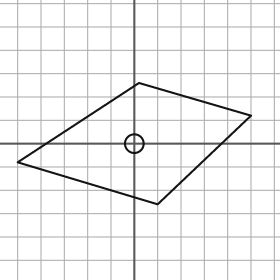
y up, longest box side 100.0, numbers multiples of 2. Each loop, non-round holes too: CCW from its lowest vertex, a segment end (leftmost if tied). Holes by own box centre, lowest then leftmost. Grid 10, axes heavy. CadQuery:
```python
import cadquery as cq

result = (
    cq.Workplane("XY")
    .moveTo(10.0, -26.0)
    .lineTo(50.0, 12.0)
    .lineTo(2.0, 26.0)
    .lineTo(-50.0, -8.0)
    .close()
    .moveTo(0.0, 0.0)
    .circle(4.0)
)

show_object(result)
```